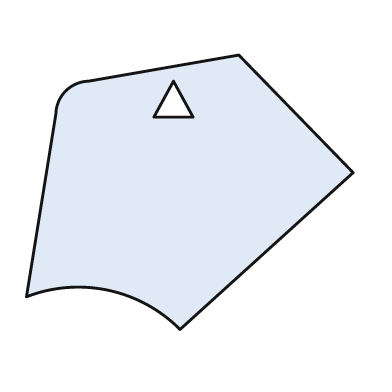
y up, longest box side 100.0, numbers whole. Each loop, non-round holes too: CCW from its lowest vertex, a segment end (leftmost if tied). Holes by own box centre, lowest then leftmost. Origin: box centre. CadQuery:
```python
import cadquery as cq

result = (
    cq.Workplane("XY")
    .moveTo(-3.0, -42.0)
    .lineTo(50.0, 6.0)
    .lineTo(15.0, 42.0)
    .lineTo(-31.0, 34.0)
    .threePointArc((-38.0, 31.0), (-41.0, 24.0))
    .lineTo(-50.0, -32.0)
    .threePointArc((-25.0, -30.0), (-3.0, -42.0))
    .close()
    .moveTo(-11.0, 23.0)
    .lineTo(1.0, 23.0)
    .lineTo(-5.0, 34.0)
    .close()
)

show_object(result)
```